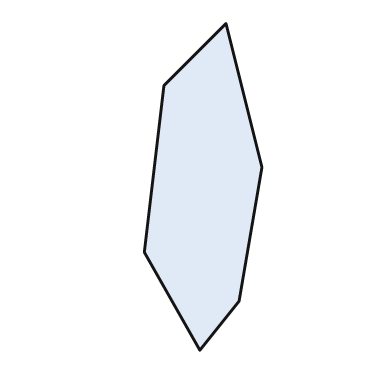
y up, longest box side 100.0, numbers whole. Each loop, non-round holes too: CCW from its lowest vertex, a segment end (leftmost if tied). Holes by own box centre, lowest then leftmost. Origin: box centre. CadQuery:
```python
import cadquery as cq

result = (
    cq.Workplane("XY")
    .moveTo(-1.0, -50.0)
    .lineTo(11.0, -35.0)
    .lineTo(18.0, 6.0)
    .lineTo(7.0, 50.0)
    .lineTo(-12.0, 31.0)
    .lineTo(-18.0, -20.0)
    .close()
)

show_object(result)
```